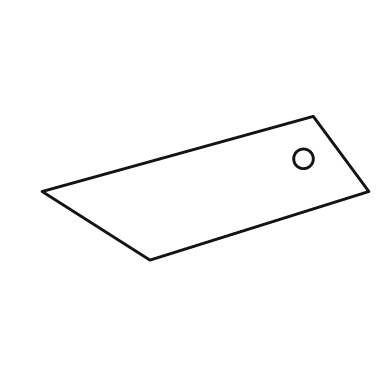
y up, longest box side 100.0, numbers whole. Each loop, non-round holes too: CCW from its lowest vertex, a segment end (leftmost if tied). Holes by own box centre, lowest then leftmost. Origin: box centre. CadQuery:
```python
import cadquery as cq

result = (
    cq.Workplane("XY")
    .moveTo(-17.0, -22.0)
    .lineTo(50.0, -1.0)
    .lineTo(33.0, 22.0)
    .lineTo(-50.0, -1.0)
    .close()
    .moveTo(30.0, 9.0)
    .circle(3.0)
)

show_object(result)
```